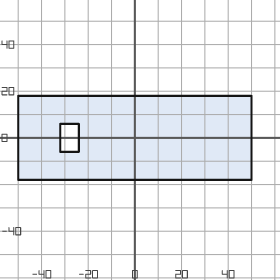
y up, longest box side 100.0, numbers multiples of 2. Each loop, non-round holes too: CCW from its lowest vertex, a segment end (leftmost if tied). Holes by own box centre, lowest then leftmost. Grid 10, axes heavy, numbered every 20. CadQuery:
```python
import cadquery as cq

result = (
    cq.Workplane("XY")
    .moveTo(-50.0, -18.0)
    .lineTo(50.0, -18.0)
    .lineTo(50.0, 18.0)
    .lineTo(-50.0, 18.0)
    .close()
    .moveTo(-32.0, -6.0)
    .lineTo(-24.0, -6.0)
    .lineTo(-24.0, 6.0)
    .lineTo(-32.0, 6.0)
    .close()
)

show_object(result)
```